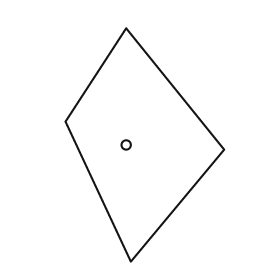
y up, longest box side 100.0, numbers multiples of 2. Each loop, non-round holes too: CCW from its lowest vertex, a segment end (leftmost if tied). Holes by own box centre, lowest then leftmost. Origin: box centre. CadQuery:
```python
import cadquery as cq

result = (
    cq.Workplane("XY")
    .moveTo(-6.0, -50.0)
    .lineTo(34.0, -2.0)
    .lineTo(-8.0, 50.0)
    .lineTo(-34.0, 10.0)
    .close()
    .moveTo(-8.0, 0.0)
    .circle(2.0)
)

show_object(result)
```